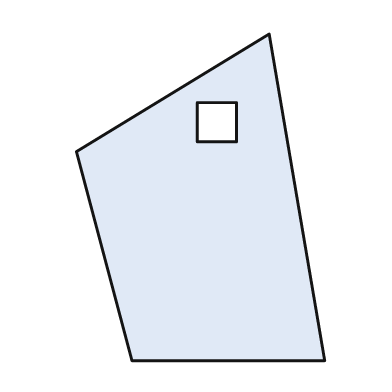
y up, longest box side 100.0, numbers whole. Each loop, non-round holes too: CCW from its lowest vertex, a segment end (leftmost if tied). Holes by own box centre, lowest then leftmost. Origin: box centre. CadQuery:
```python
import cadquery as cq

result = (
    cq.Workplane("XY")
    .moveTo(-21.0, -50.0)
    .lineTo(38.0, -50.0)
    .lineTo(21.0, 50.0)
    .lineTo(-38.0, 14.0)
    .close()
    .moveTo(-1.0, 17.0)
    .lineTo(11.0, 17.0)
    .lineTo(11.0, 29.0)
    .lineTo(-1.0, 29.0)
    .close()
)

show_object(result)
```